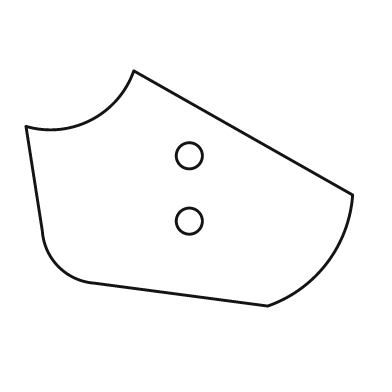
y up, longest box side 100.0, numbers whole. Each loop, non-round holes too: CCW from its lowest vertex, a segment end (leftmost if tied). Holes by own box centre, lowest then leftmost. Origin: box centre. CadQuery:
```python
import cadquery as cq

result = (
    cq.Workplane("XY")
    .moveTo(24.0, -36.0)
    .threePointArc((42.0, -23.0), (50.0, -2.0))
    .lineTo(-17.0, 36.0)
    .threePointArc((-30.0, 21.0), (-50.0, 19.0))
    .lineTo(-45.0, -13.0)
    .threePointArc((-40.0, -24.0), (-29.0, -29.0))
    .close()
    .moveTo(0.0, -10.0)
    .circle(4.0)
    .moveTo(0.0, 10.0)
    .circle(4.0)
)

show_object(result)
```